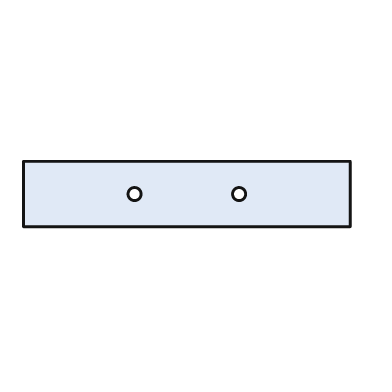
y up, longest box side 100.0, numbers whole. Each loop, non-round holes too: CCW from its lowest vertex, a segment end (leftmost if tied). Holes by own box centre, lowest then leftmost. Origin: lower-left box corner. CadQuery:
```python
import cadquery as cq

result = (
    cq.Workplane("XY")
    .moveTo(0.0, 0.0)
    .lineTo(100.0, 0.0)
    .lineTo(100.0, 20.0)
    .lineTo(0.0, 20.0)
    .close()
    .moveTo(34.0, 10.0)
    .circle(2.0)
    .moveTo(66.0, 10.0)
    .circle(2.0)
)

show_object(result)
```